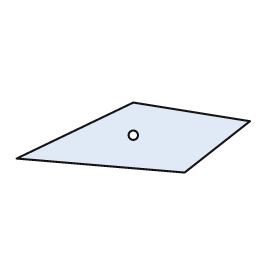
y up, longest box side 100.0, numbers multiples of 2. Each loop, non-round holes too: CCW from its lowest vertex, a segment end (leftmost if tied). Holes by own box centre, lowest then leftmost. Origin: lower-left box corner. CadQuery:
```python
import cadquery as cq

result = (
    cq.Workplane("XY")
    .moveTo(72.0, 0.0)
    .lineTo(100.0, 22.0)
    .lineTo(50.0, 30.0)
    .lineTo(0.0, 6.0)
    .close()
    .moveTo(50.0, 16.0)
    .circle(2.0)
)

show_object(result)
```